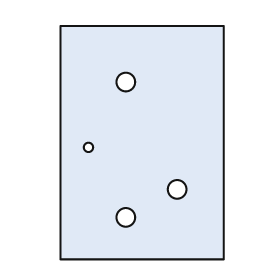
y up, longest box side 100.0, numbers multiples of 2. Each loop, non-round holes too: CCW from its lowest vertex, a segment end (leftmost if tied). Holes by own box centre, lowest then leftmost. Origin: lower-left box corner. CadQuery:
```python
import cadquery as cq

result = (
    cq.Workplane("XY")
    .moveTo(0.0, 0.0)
    .lineTo(70.0, 0.0)
    .lineTo(70.0, 100.0)
    .lineTo(0.0, 100.0)
    .close()
    .moveTo(28.0, 18.0)
    .circle(4.0)
    .moveTo(50.0, 30.0)
    .circle(4.0)
    .moveTo(12.0, 48.0)
    .circle(2.0)
    .moveTo(28.0, 76.0)
    .circle(4.0)
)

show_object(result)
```